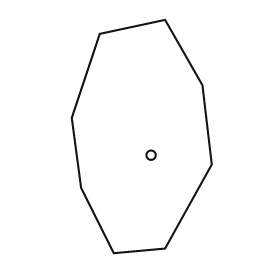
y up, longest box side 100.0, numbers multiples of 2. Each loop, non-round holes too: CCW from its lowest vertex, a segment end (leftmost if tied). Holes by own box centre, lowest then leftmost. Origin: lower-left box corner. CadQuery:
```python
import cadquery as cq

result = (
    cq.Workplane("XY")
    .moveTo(18.0, 0.0)
    .lineTo(40.0, 2.0)
    .lineTo(60.0, 38.0)
    .lineTo(56.0, 72.0)
    .lineTo(40.0, 100.0)
    .lineTo(12.0, 94.0)
    .lineTo(0.0, 58.0)
    .lineTo(4.0, 28.0)
    .close()
    .moveTo(34.0, 42.0)
    .circle(2.0)
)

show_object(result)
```